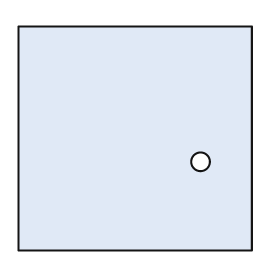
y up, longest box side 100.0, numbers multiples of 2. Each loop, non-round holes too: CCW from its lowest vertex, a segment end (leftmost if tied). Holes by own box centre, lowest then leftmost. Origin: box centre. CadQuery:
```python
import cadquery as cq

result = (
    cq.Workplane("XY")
    .moveTo(-50.0, -48.0)
    .lineTo(50.0, -48.0)
    .lineTo(50.0, 48.0)
    .lineTo(-50.0, 48.0)
    .close()
    .moveTo(28.0, -10.0)
    .circle(4.0)
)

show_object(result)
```